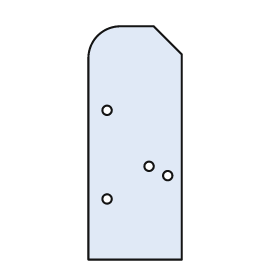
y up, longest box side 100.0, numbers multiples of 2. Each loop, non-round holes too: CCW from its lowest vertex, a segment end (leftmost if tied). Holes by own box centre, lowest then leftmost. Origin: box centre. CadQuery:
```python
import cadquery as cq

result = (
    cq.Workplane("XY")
    .moveTo(-20.0, -50.0)
    .lineTo(20.0, -50.0)
    .lineTo(20.0, 38.0)
    .lineTo(8.0, 50.0)
    .lineTo(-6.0, 50.0)
    .threePointArc((-16.0, 46.0), (-20.0, 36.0))
    .close()
    .moveTo(-12.0, -24.0)
    .circle(2.0)
    .moveTo(14.0, -14.0)
    .circle(2.0)
    .moveTo(6.0, -10.0)
    .circle(2.0)
    .moveTo(-12.0, 14.0)
    .circle(2.0)
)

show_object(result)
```